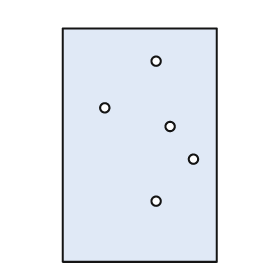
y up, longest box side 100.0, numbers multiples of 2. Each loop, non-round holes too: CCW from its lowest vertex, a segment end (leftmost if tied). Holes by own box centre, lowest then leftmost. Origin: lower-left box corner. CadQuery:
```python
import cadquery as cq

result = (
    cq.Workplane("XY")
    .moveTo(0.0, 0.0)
    .lineTo(66.0, 0.0)
    .lineTo(66.0, 100.0)
    .lineTo(0.0, 100.0)
    .close()
    .moveTo(40.0, 26.0)
    .circle(2.0)
    .moveTo(56.0, 44.0)
    .circle(2.0)
    .moveTo(46.0, 58.0)
    .circle(2.0)
    .moveTo(18.0, 66.0)
    .circle(2.0)
    .moveTo(40.0, 86.0)
    .circle(2.0)
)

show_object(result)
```